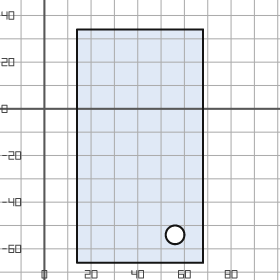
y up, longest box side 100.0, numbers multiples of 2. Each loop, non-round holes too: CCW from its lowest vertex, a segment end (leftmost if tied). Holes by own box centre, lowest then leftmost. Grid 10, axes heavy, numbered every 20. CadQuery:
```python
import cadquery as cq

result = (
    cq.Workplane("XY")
    .moveTo(14.0, -66.0)
    .lineTo(68.0, -66.0)
    .lineTo(68.0, 34.0)
    .lineTo(14.0, 34.0)
    .close()
    .moveTo(56.0, -54.0)
    .circle(4.0)
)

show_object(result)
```